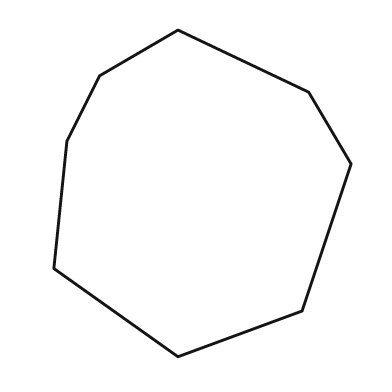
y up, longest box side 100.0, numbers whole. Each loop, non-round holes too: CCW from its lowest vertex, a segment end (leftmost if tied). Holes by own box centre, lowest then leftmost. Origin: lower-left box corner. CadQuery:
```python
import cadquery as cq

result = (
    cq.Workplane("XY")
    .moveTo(38.0, 0.0)
    .lineTo(76.0, 14.0)
    .lineTo(91.0, 59.0)
    .lineTo(78.0, 81.0)
    .lineTo(38.0, 100.0)
    .lineTo(14.0, 86.0)
    .lineTo(4.0, 66.0)
    .lineTo(0.0, 27.0)
    .close()
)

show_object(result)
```